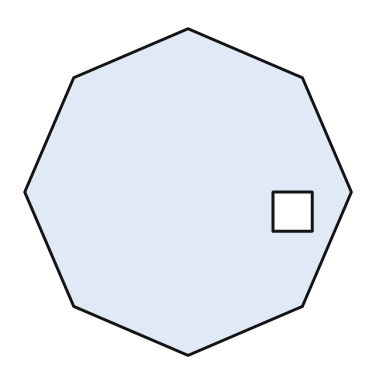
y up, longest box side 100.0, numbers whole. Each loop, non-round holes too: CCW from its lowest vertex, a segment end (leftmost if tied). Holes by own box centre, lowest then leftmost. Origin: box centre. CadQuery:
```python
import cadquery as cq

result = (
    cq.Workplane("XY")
    .moveTo(0.0, -50.0)
    .lineTo(35.0, -35.0)
    .lineTo(50.0, 0.0)
    .lineTo(35.0, 35.0)
    .lineTo(0.0, 50.0)
    .lineTo(-35.0, 35.0)
    .lineTo(-50.0, 0.0)
    .lineTo(-35.0, -35.0)
    .close()
    .moveTo(26.0, -12.0)
    .lineTo(38.0, -12.0)
    .lineTo(38.0, 0.0)
    .lineTo(26.0, 0.0)
    .close()
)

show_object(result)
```